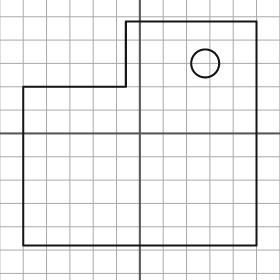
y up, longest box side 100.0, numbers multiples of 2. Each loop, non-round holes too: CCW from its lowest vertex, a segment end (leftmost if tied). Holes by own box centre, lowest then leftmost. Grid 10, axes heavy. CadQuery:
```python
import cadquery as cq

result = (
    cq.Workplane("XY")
    .moveTo(-50.0, -48.0)
    .lineTo(50.0, -48.0)
    .lineTo(50.0, 48.0)
    .lineTo(-6.0, 48.0)
    .lineTo(-6.0, 20.0)
    .lineTo(-50.0, 20.0)
    .close()
    .moveTo(28.0, 30.0)
    .circle(6.0)
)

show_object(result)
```